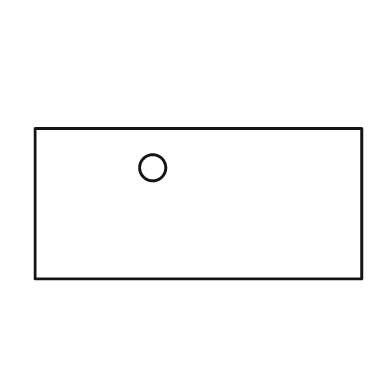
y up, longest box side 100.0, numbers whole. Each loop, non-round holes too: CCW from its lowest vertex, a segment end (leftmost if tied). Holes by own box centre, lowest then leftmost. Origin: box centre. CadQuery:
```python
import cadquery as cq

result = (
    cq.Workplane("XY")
    .moveTo(-50.0, -23.0)
    .lineTo(50.0, -23.0)
    .lineTo(50.0, 23.0)
    .lineTo(-50.0, 23.0)
    .close()
    .moveTo(-14.0, 11.0)
    .circle(4.0)
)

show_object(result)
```